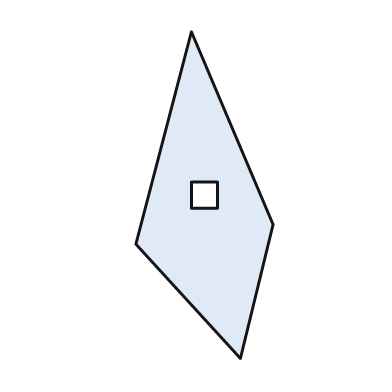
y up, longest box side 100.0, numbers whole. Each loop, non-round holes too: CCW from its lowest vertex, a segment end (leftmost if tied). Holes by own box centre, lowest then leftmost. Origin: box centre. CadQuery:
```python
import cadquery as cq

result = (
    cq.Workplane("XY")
    .moveTo(11.0, -50.0)
    .lineTo(21.0, -9.0)
    .lineTo(-4.0, 50.0)
    .lineTo(-21.0, -15.0)
    .close()
    .moveTo(-4.0, -4.0)
    .lineTo(4.0, -4.0)
    .lineTo(4.0, 4.0)
    .lineTo(-4.0, 4.0)
    .close()
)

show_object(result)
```